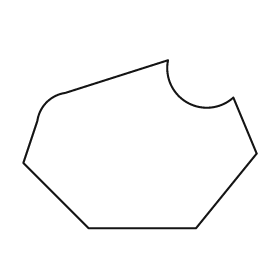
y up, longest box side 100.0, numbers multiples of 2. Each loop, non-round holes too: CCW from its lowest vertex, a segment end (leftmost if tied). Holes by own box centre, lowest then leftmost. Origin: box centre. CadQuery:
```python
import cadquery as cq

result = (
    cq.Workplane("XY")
    .moveTo(-22.0, -36.0)
    .lineTo(24.0, -36.0)
    .lineTo(50.0, -4.0)
    .lineTo(40.0, 20.0)
    .threePointArc((20.0, 18.0), (12.0, 36.0))
    .lineTo(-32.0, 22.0)
    .threePointArc((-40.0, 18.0), (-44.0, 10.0))
    .lineTo(-50.0, -8.0)
    .close()
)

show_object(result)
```